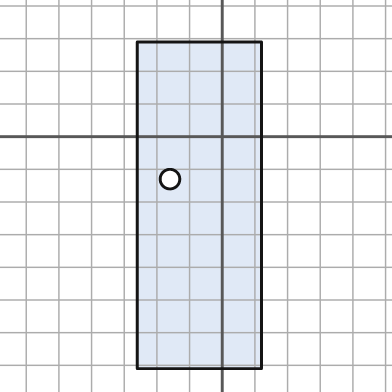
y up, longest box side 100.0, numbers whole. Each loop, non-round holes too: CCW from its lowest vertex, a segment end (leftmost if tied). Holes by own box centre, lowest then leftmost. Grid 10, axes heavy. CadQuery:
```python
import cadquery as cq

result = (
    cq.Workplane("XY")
    .moveTo(-26.0, -71.0)
    .lineTo(12.0, -71.0)
    .lineTo(12.0, 29.0)
    .lineTo(-26.0, 29.0)
    .close()
    .moveTo(-16.0, -13.0)
    .circle(3.0)
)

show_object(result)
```